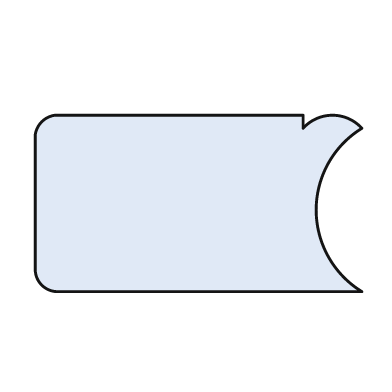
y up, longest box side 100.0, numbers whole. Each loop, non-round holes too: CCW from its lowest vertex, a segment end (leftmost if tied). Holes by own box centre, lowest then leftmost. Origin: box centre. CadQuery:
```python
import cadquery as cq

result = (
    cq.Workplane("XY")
    .moveTo(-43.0, -27.0)
    .lineTo(50.0, -27.0)
    .threePointArc((36.0, -2.0), (50.0, 23.0))
    .threePointArc((41.0, 27.0), (32.0, 23.0))
    .lineTo(32.0, 27.0)
    .lineTo(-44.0, 27.0)
    .threePointArc((-48.0, 25.0), (-50.0, 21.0))
    .lineTo(-50.0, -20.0)
    .threePointArc((-48.0, -25.0), (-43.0, -27.0))
    .close()
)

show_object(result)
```